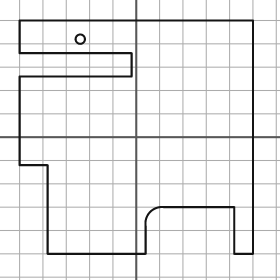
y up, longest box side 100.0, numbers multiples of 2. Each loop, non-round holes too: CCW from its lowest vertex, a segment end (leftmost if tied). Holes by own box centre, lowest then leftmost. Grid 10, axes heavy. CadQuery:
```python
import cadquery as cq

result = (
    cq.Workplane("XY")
    .moveTo(-38.0, -50.0)
    .lineTo(4.0, -50.0)
    .lineTo(4.0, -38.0)
    .threePointArc((6.0, -32.0), (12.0, -30.0))
    .lineTo(42.0, -30.0)
    .lineTo(42.0, -50.0)
    .lineTo(50.0, -50.0)
    .lineTo(50.0, 50.0)
    .lineTo(-50.0, 50.0)
    .lineTo(-50.0, 36.0)
    .lineTo(-2.0, 36.0)
    .lineTo(-2.0, 26.0)
    .lineTo(-50.0, 26.0)
    .lineTo(-50.0, -12.0)
    .lineTo(-38.0, -12.0)
    .close()
    .moveTo(-24.0, 42.0)
    .circle(2.0)
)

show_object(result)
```